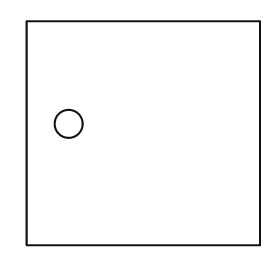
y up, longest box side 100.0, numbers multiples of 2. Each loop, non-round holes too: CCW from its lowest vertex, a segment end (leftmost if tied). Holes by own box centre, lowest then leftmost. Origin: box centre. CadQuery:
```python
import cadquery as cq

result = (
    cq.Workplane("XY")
    .moveTo(-50.0, -48.0)
    .lineTo(50.0, -48.0)
    .lineTo(50.0, 48.0)
    .lineTo(-50.0, 48.0)
    .close()
    .moveTo(-32.0, 4.0)
    .circle(6.0)
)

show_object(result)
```